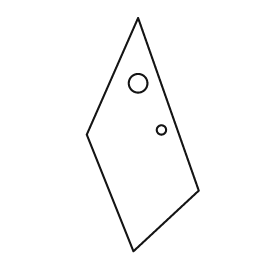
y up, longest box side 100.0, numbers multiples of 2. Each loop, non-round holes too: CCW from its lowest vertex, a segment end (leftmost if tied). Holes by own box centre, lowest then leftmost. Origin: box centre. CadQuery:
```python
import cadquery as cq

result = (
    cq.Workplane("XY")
    .moveTo(-4.0, -50.0)
    .lineTo(24.0, -24.0)
    .lineTo(-2.0, 50.0)
    .lineTo(-24.0, 0.0)
    .close()
    .moveTo(8.0, 2.0)
    .circle(2.0)
    .moveTo(-2.0, 22.0)
    .circle(4.0)
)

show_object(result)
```